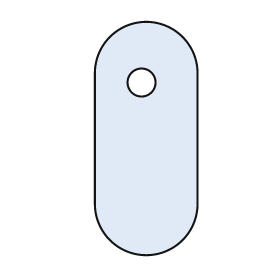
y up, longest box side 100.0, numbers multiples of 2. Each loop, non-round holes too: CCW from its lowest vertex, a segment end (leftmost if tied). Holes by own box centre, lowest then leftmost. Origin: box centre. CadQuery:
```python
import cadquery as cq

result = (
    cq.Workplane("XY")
    .moveTo(-22.0, -28.0)
    .threePointArc((0.0, -50.0), (22.0, -28.0))
    .lineTo(22.0, 28.0)
    .threePointArc((0.0, 50.0), (-22.0, 28.0))
    .close()
    .moveTo(-2.0, 24.0)
    .circle(6.0)
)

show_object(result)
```